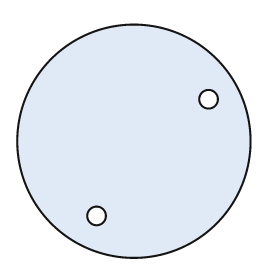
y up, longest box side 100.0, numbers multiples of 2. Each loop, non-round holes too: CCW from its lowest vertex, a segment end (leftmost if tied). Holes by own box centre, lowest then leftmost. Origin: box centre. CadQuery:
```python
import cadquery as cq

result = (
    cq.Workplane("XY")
    .moveTo(0.0, 0.0)
    .circle(50.0)
    .moveTo(-16.0, -32.0)
    .circle(4.0)
    .moveTo(32.0, 18.0)
    .circle(4.0)
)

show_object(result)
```